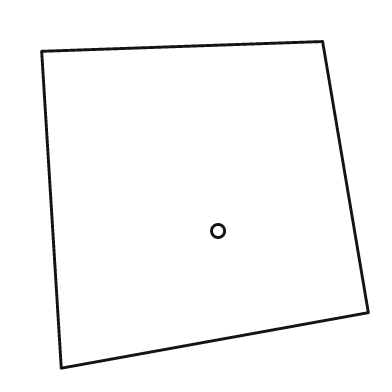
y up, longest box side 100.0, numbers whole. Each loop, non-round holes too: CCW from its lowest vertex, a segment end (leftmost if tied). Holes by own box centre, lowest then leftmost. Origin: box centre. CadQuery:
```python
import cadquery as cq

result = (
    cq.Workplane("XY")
    .moveTo(-44.0, -50.0)
    .lineTo(50.0, -33.0)
    .lineTo(36.0, 50.0)
    .lineTo(-50.0, 47.0)
    .close()
    .moveTo(4.0, -8.0)
    .circle(2.0)
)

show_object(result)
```